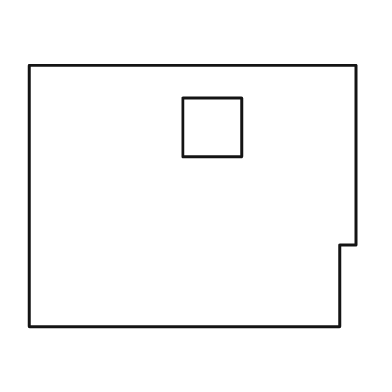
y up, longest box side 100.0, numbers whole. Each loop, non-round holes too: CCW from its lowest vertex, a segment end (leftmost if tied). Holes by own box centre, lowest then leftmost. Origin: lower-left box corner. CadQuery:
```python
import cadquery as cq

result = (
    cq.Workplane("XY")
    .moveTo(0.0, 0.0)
    .lineTo(95.0, 0.0)
    .lineTo(95.0, 25.0)
    .lineTo(100.0, 25.0)
    .lineTo(100.0, 80.0)
    .lineTo(0.0, 80.0)
    .close()
    .moveTo(47.0, 52.0)
    .lineTo(65.0, 52.0)
    .lineTo(65.0, 70.0)
    .lineTo(47.0, 70.0)
    .close()
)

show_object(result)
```